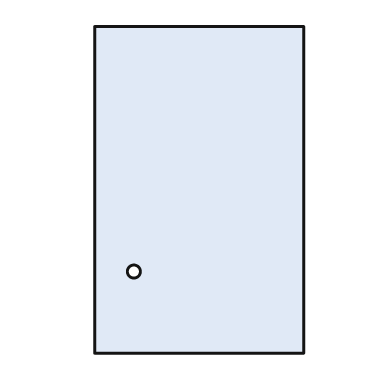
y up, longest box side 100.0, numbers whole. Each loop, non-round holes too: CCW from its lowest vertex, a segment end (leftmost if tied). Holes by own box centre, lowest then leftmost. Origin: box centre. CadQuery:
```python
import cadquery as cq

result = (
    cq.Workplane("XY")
    .moveTo(-32.0, -50.0)
    .lineTo(32.0, -50.0)
    .lineTo(32.0, 50.0)
    .lineTo(-32.0, 50.0)
    .close()
    .moveTo(-20.0, -25.0)
    .circle(2.0)
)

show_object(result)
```